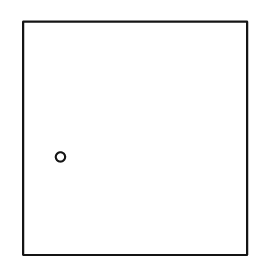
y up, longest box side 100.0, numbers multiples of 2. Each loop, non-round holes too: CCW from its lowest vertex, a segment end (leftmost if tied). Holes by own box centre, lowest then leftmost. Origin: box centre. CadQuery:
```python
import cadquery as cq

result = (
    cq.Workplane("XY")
    .moveTo(-48.0, -50.0)
    .lineTo(48.0, -50.0)
    .lineTo(48.0, 50.0)
    .lineTo(-48.0, 50.0)
    .close()
    .moveTo(-32.0, -8.0)
    .circle(2.0)
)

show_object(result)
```